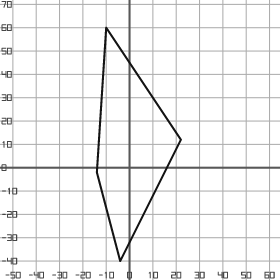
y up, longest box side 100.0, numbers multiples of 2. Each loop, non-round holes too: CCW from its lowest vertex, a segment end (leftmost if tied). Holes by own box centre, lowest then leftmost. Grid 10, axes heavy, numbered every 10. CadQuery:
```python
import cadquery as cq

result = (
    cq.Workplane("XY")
    .moveTo(-4.0, -40.0)
    .lineTo(22.0, 12.0)
    .lineTo(-10.0, 60.0)
    .lineTo(-14.0, -2.0)
    .close()
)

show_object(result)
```